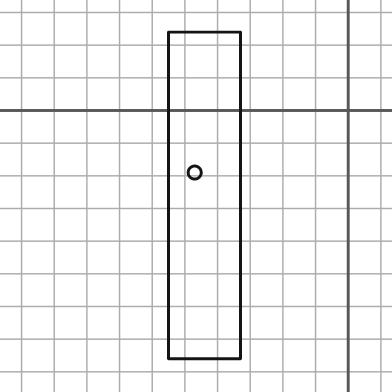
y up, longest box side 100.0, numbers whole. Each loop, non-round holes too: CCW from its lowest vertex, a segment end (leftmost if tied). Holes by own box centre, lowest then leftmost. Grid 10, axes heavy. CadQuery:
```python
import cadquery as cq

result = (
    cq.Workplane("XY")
    .moveTo(-55.0, -76.0)
    .lineTo(-33.0, -76.0)
    .lineTo(-33.0, 24.0)
    .lineTo(-55.0, 24.0)
    .close()
    .moveTo(-47.0, -19.0)
    .circle(2.0)
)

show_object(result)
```